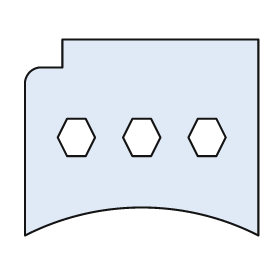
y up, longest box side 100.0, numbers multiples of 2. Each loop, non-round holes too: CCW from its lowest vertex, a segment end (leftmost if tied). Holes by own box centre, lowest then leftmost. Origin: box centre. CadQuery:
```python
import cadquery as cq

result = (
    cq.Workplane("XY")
    .moveTo(-50.0, -42.0)
    .threePointArc((0.0, -30.0), (50.0, -42.0))
    .lineTo(50.0, 42.0)
    .lineTo(-34.0, 42.0)
    .lineTo(-34.0, 30.0)
    .lineTo(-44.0, 30.0)
    .threePointArc((-48.0, 28.0), (-50.0, 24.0))
    .close()
    .moveTo(-32.0, -8.0)
    .lineTo(-24.0, -8.0)
    .lineTo(-20.0, 0.0)
    .lineTo(-24.0, 8.0)
    .lineTo(-32.0, 8.0)
    .lineTo(-36.0, 0.0)
    .close()
    .moveTo(-4.0, -8.0)
    .lineTo(4.0, -8.0)
    .lineTo(8.0, 0.0)
    .lineTo(4.0, 8.0)
    .lineTo(-4.0, 8.0)
    .lineTo(-8.0, 0.0)
    .close()
    .moveTo(24.0, -8.0)
    .lineTo(32.0, -8.0)
    .lineTo(36.0, 0.0)
    .lineTo(32.0, 8.0)
    .lineTo(24.0, 8.0)
    .lineTo(20.0, 0.0)
    .close()
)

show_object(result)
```